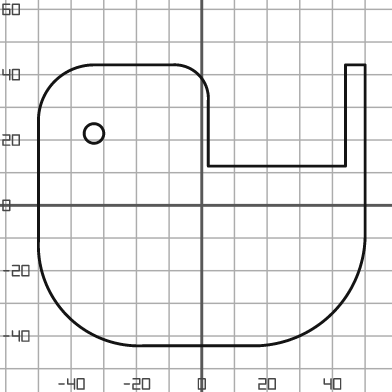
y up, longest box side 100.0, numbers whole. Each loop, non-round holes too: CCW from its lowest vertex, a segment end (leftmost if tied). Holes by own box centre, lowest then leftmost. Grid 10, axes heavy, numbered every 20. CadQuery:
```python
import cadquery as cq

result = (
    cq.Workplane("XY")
    .moveTo(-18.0, -43.0)
    .lineTo(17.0, -43.0)
    .threePointArc((40.0, -33.0), (50.0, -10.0))
    .lineTo(50.0, 43.0)
    .lineTo(44.0, 43.0)
    .lineTo(44.0, 12.0)
    .lineTo(2.0, 12.0)
    .lineTo(2.0, 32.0)
    .threePointArc((-1.0, 40.0), (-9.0, 43.0))
    .lineTo(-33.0, 43.0)
    .threePointArc((-45.0, 38.0), (-50.0, 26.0))
    .lineTo(-50.0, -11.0)
    .threePointArc((-41.0, -34.0), (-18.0, -43.0))
    .close()
    .moveTo(-33.0, 22.0)
    .circle(3.0)
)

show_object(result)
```